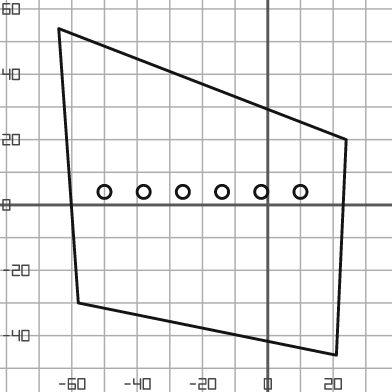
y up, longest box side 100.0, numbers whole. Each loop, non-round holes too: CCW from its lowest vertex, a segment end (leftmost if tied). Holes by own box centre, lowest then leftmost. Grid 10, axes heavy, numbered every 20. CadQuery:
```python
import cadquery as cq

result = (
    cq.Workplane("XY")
    .moveTo(21.0, -46.0)
    .lineTo(24.0, 20.0)
    .lineTo(-64.0, 54.0)
    .lineTo(-58.0, -30.0)
    .close()
    .moveTo(-50.0, 4.0)
    .circle(2.0)
    .moveTo(-38.0, 4.0)
    .circle(2.0)
    .moveTo(-26.0, 4.0)
    .circle(2.0)
    .moveTo(-14.0, 4.0)
    .circle(2.0)
    .moveTo(-2.0, 4.0)
    .circle(2.0)
    .moveTo(10.0, 4.0)
    .circle(2.0)
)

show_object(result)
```